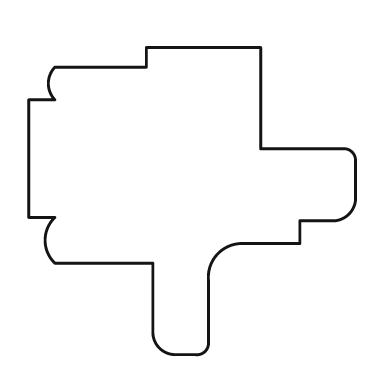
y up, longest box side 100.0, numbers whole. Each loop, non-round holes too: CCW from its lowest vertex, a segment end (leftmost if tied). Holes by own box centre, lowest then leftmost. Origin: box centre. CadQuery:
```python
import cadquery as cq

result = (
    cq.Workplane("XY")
    .moveTo(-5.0, -47.0)
    .lineTo(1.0, -47.0)
    .threePointArc((4.0, -46.0), (5.0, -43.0))
    .lineTo(5.0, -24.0)
    .threePointArc((8.0, -16.0), (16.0, -13.0))
    .lineTo(33.0, -13.0)
    .lineTo(33.0, -6.0)
    .lineTo(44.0, -6.0)
    .threePointArc((48.0, -4.0), (50.0, 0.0))
    .lineTo(50.0, 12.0)
    .threePointArc((49.0, 15.0), (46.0, 16.0))
    .lineTo(21.0, 16.0)
    .lineTo(21.0, 47.0)
    .lineTo(-14.0, 47.0)
    .lineTo(-14.0, 41.0)
    .lineTo(-42.0, 41.0)
    .threePointArc((-44.0, 36.0), (-42.0, 31.0))
    .lineTo(-50.0, 31.0)
    .lineTo(-50.0, -5.0)
    .lineTo(-42.0, -5.0)
    .threePointArc((-45.0, -12.0), (-42.0, -19.0))
    .lineTo(-12.0, -19.0)
    .lineTo(-12.0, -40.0)
    .threePointArc((-10.0, -45.0), (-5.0, -47.0))
    .close()
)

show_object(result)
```